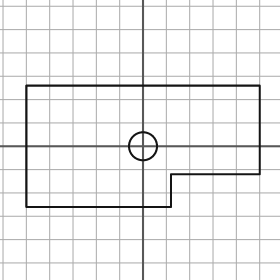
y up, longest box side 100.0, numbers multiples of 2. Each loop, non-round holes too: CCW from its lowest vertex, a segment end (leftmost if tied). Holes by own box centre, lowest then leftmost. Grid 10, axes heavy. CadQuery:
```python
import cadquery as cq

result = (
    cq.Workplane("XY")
    .moveTo(-50.0, -26.0)
    .lineTo(12.0, -26.0)
    .lineTo(12.0, -12.0)
    .lineTo(50.0, -12.0)
    .lineTo(50.0, 26.0)
    .lineTo(-50.0, 26.0)
    .close()
    .moveTo(0.0, 0.0)
    .circle(6.0)
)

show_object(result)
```